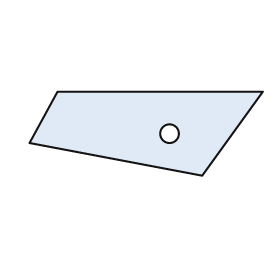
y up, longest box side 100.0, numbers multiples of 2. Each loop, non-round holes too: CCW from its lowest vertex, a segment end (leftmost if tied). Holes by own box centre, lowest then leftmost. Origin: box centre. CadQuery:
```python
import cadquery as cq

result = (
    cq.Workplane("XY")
    .moveTo(24.0, -18.0)
    .lineTo(50.0, 18.0)
    .lineTo(-38.0, 18.0)
    .lineTo(-50.0, -4.0)
    .close()
    .moveTo(10.0, 0.0)
    .circle(4.0)
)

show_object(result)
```